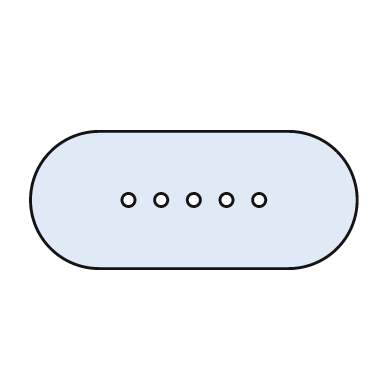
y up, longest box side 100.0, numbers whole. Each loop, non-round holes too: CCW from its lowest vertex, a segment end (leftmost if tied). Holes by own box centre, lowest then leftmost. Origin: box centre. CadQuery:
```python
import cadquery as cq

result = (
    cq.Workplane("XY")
    .moveTo(-29.0, -21.0)
    .lineTo(29.0, -21.0)
    .threePointArc((50.0, 0.0), (29.0, 21.0))
    .lineTo(-29.0, 21.0)
    .threePointArc((-50.0, 0.0), (-29.0, -21.0))
    .close()
    .moveTo(-20.0, 0.0)
    .circle(2.0)
    .moveTo(-10.0, 0.0)
    .circle(2.0)
    .moveTo(0.0, 0.0)
    .circle(2.0)
    .moveTo(10.0, 0.0)
    .circle(2.0)
    .moveTo(20.0, 0.0)
    .circle(2.0)
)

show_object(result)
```